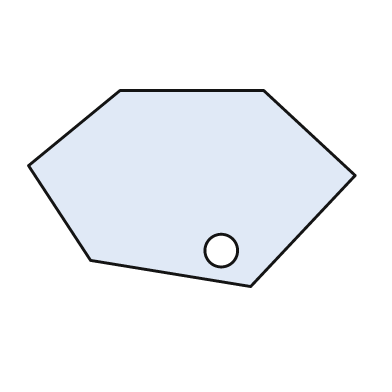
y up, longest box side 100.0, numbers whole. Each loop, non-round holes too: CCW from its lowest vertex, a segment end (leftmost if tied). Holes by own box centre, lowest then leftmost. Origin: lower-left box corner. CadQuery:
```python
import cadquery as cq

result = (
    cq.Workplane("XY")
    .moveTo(68.0, 0.0)
    .lineTo(100.0, 34.0)
    .lineTo(72.0, 60.0)
    .lineTo(28.0, 60.0)
    .lineTo(0.0, 37.0)
    .lineTo(19.0, 8.0)
    .close()
    .moveTo(59.0, 11.0)
    .circle(5.0)
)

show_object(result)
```